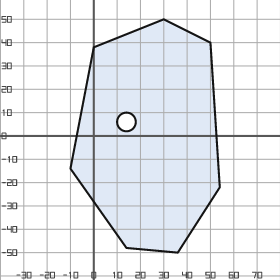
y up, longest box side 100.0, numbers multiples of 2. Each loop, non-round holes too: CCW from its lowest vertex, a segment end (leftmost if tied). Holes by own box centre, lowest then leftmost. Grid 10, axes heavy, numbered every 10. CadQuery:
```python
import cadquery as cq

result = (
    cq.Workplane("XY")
    .moveTo(36.0, -50.0)
    .lineTo(54.0, -22.0)
    .lineTo(50.0, 40.0)
    .lineTo(30.0, 50.0)
    .lineTo(0.0, 38.0)
    .lineTo(-10.0, -14.0)
    .lineTo(14.0, -48.0)
    .close()
    .moveTo(14.0, 6.0)
    .circle(4.0)
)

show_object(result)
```